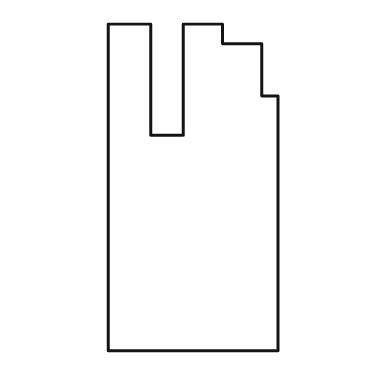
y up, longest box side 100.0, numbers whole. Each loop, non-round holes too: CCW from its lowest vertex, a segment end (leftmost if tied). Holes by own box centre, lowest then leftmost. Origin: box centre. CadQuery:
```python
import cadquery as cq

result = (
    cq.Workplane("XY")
    .moveTo(-26.0, -50.0)
    .lineTo(26.0, -50.0)
    .lineTo(26.0, 28.0)
    .lineTo(21.0, 28.0)
    .lineTo(21.0, 44.0)
    .lineTo(9.0, 44.0)
    .lineTo(9.0, 50.0)
    .lineTo(-3.0, 50.0)
    .lineTo(-3.0, 16.0)
    .lineTo(-13.0, 16.0)
    .lineTo(-13.0, 50.0)
    .lineTo(-26.0, 50.0)
    .close()
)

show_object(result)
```